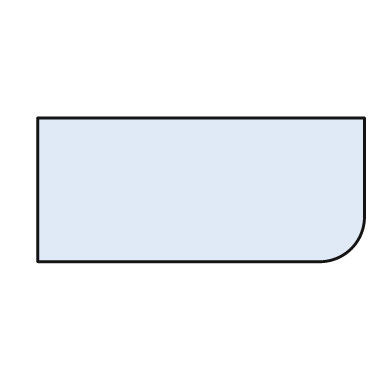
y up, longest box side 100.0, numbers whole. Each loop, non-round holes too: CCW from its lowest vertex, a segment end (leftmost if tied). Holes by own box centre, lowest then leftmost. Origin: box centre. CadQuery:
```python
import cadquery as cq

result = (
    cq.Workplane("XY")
    .moveTo(-50.0, -22.0)
    .lineTo(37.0, -22.0)
    .threePointArc((46.0, -18.0), (50.0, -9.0))
    .lineTo(50.0, 22.0)
    .lineTo(-50.0, 22.0)
    .close()
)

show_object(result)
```